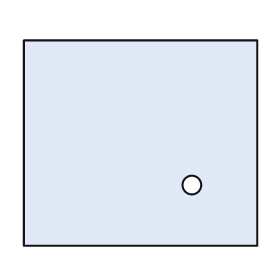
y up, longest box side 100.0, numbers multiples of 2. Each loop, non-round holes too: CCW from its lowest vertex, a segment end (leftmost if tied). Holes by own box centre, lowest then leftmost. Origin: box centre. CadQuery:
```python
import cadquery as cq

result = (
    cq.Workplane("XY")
    .moveTo(-50.0, -44.0)
    .lineTo(50.0, -44.0)
    .lineTo(50.0, 44.0)
    .lineTo(-50.0, 44.0)
    .close()
    .moveTo(22.0, -18.0)
    .circle(4.0)
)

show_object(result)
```